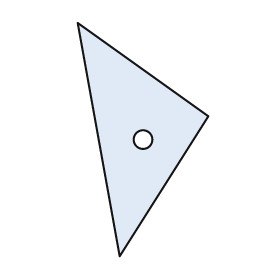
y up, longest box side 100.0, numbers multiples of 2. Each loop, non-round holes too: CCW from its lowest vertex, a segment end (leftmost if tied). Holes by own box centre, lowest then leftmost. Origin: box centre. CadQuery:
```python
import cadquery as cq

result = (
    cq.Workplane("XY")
    .moveTo(-10.0, -50.0)
    .lineTo(28.0, 10.0)
    .lineTo(-28.0, 50.0)
    .close()
    .moveTo(0.0, 0.0)
    .circle(4.0)
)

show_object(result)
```